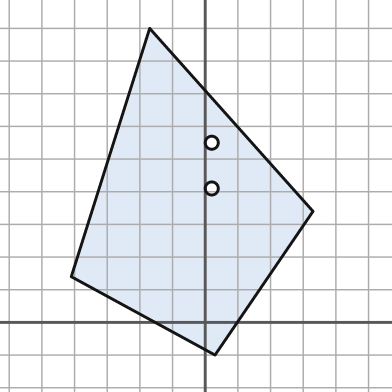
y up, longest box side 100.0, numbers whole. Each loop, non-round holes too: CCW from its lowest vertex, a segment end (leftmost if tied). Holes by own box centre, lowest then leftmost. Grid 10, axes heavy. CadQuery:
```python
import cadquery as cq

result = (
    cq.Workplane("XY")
    .moveTo(3.0, -10.0)
    .lineTo(33.0, 34.0)
    .lineTo(-17.0, 90.0)
    .lineTo(-41.0, 14.0)
    .close()
    .moveTo(2.0, 41.0)
    .circle(2.0)
    .moveTo(2.0, 55.0)
    .circle(2.0)
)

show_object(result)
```